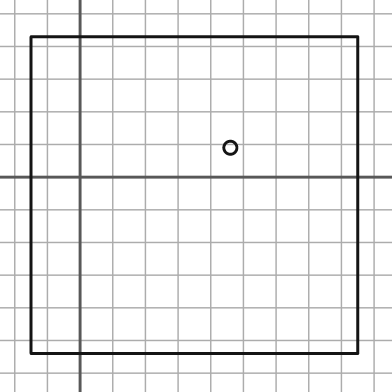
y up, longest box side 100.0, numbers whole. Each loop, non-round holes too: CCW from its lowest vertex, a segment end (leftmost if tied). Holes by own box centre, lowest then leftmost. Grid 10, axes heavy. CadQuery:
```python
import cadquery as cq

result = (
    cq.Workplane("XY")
    .moveTo(-15.0, -54.0)
    .lineTo(85.0, -54.0)
    .lineTo(85.0, 43.0)
    .lineTo(-15.0, 43.0)
    .close()
    .moveTo(46.0, 9.0)
    .circle(2.0)
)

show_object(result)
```